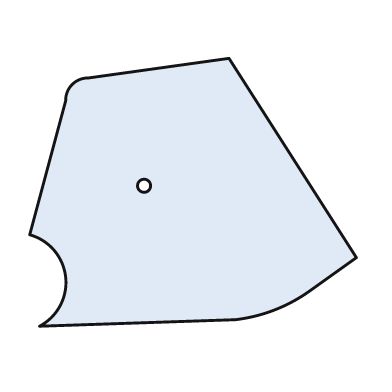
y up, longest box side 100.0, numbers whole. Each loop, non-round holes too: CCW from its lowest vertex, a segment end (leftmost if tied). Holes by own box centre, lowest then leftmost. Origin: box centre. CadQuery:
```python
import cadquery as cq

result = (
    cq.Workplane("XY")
    .moveTo(-47.0, -41.0)
    .lineTo(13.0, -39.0)
    .threePointArc((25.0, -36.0), (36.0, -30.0))
    .lineTo(50.0, -20.0)
    .lineTo(11.0, 41.0)
    .lineTo(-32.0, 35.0)
    .threePointArc((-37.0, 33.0), (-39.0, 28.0))
    .lineTo(-50.0, -13.0)
    .threePointArc((-39.0, -26.0), (-47.0, -41.0))
    .close()
    .moveTo(-15.0, 2.0)
    .circle(2.0)
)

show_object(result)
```